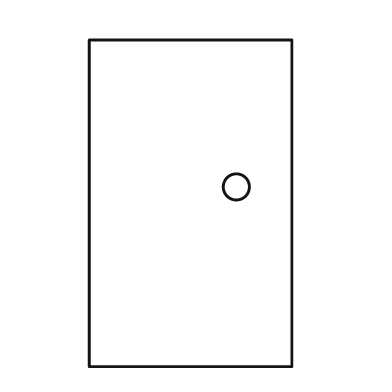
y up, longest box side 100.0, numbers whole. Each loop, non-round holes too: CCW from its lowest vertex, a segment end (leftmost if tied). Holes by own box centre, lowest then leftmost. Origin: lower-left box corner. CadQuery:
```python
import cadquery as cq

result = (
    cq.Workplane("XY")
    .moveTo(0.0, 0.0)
    .lineTo(62.0, 0.0)
    .lineTo(62.0, 100.0)
    .lineTo(0.0, 100.0)
    .close()
    .moveTo(45.0, 55.0)
    .circle(4.0)
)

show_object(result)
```